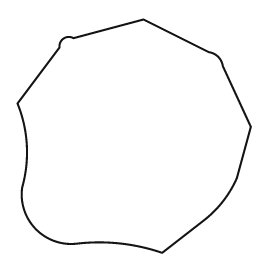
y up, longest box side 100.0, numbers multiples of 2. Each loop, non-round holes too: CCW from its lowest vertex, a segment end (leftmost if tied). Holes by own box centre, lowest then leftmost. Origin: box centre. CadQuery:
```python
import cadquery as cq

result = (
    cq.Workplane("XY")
    .moveTo(12.0, -50.0)
    .lineTo(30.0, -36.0)
    .threePointArc((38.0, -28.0), (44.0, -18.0))
    .lineTo(50.0, 4.0)
    .lineTo(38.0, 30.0)
    .threePointArc((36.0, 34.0), (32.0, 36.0))
    .lineTo(4.0, 50.0)
    .lineTo(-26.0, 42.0)
    .threePointArc((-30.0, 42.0), (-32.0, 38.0))
    .lineTo(-50.0, 14.0)
    .threePointArc((-46.0, -4.0), (-48.0, -22.0))
    .threePointArc((-42.0, -40.0), (-24.0, -46.0))
    .threePointArc((-6.0, -46.0), (12.0, -50.0))
    .close()
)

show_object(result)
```